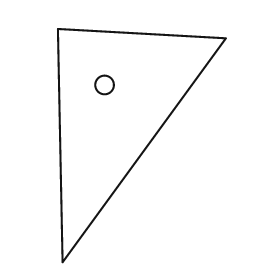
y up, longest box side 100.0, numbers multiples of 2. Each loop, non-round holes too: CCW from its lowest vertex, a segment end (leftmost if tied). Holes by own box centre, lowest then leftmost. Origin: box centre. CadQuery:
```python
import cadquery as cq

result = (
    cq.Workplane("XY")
    .moveTo(-34.0, -50.0)
    .lineTo(36.0, 46.0)
    .lineTo(-36.0, 50.0)
    .close()
    .moveTo(-16.0, 26.0)
    .circle(4.0)
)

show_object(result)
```